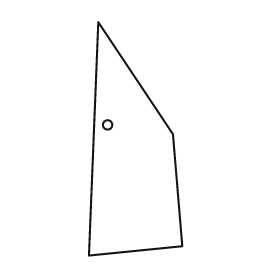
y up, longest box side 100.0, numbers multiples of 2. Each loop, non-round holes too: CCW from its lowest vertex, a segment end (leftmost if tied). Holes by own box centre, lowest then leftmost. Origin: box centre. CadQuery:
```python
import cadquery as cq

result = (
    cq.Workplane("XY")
    .moveTo(-20.0, -50.0)
    .lineTo(20.0, -46.0)
    .lineTo(16.0, 2.0)
    .lineTo(-16.0, 50.0)
    .close()
    .moveTo(-12.0, 6.0)
    .circle(2.0)
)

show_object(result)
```